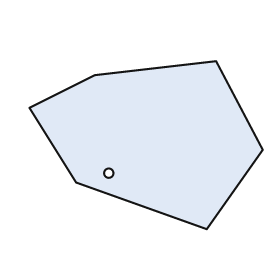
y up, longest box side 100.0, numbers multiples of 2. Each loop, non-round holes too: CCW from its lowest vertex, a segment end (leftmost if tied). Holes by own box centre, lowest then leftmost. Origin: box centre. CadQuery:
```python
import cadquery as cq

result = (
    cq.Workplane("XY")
    .moveTo(26.0, -36.0)
    .lineTo(50.0, -2.0)
    .lineTo(30.0, 36.0)
    .lineTo(-22.0, 30.0)
    .lineTo(-50.0, 16.0)
    .lineTo(-30.0, -16.0)
    .close()
    .moveTo(-16.0, -12.0)
    .circle(2.0)
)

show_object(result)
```